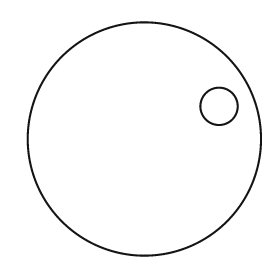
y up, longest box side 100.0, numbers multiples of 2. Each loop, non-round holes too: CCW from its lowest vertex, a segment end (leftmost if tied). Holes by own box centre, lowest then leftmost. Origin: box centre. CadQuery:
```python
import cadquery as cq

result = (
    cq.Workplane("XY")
    .moveTo(0.0, 0.0)
    .circle(50.0)
    .moveTo(32.0, 14.0)
    .circle(8.0)
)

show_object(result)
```